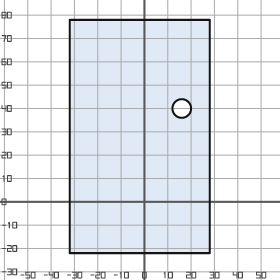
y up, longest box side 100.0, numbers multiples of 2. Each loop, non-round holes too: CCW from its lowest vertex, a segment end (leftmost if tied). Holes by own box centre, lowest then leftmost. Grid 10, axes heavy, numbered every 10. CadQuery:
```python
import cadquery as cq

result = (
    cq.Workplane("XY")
    .moveTo(-32.0, -22.0)
    .lineTo(28.0, -22.0)
    .lineTo(28.0, 78.0)
    .lineTo(-32.0, 78.0)
    .close()
    .moveTo(16.0, 40.0)
    .circle(4.0)
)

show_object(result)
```